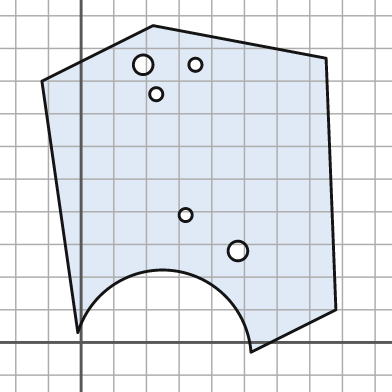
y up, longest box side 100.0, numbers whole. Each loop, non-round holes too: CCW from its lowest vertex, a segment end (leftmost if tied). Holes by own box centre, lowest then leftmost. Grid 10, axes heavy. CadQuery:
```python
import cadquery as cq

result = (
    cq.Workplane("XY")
    .moveTo(52.0, -3.0)
    .lineTo(78.0, 10.0)
    .lineTo(75.0, 87.0)
    .lineTo(22.0, 97.0)
    .lineTo(-12.0, 80.0)
    .lineTo(-1.0, 3.0)
    .threePointArc((28.0, 22.0), (52.0, -3.0))
    .close()
    .moveTo(48.0, 28.0)
    .circle(3.0)
    .moveTo(32.0, 39.0)
    .circle(2.0)
    .moveTo(23.0, 76.0)
    .circle(2.0)
    .moveTo(19.0, 85.0)
    .circle(3.0)
    .moveTo(35.0, 85.0)
    .circle(2.0)
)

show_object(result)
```